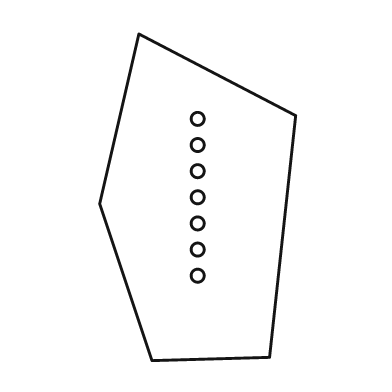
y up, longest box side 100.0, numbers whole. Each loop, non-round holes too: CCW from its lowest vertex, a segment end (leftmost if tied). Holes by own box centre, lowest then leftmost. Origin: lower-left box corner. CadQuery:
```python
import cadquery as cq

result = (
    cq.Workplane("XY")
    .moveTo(16.0, 0.0)
    .lineTo(52.0, 1.0)
    .lineTo(60.0, 75.0)
    .lineTo(12.0, 100.0)
    .lineTo(0.0, 48.0)
    .close()
    .moveTo(30.0, 26.0)
    .circle(2.0)
    .moveTo(30.0, 34.0)
    .circle(2.0)
    .moveTo(30.0, 42.0)
    .circle(2.0)
    .moveTo(30.0, 50.0)
    .circle(2.0)
    .moveTo(30.0, 58.0)
    .circle(2.0)
    .moveTo(30.0, 66.0)
    .circle(2.0)
    .moveTo(30.0, 74.0)
    .circle(2.0)
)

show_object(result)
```